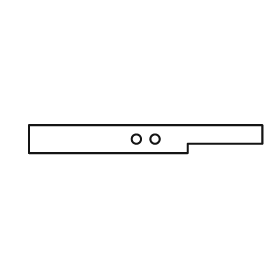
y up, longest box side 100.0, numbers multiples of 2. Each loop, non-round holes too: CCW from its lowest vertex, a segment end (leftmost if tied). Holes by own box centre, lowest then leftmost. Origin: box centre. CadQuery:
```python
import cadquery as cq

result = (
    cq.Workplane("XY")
    .moveTo(-50.0, -6.0)
    .lineTo(18.0, -6.0)
    .lineTo(18.0, -2.0)
    .lineTo(50.0, -2.0)
    .lineTo(50.0, 6.0)
    .lineTo(-50.0, 6.0)
    .close()
    .moveTo(-4.0, 0.0)
    .circle(2.0)
    .moveTo(4.0, 0.0)
    .circle(2.0)
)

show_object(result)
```